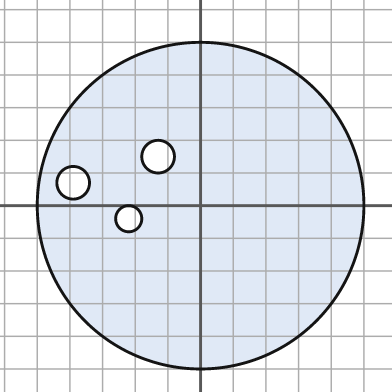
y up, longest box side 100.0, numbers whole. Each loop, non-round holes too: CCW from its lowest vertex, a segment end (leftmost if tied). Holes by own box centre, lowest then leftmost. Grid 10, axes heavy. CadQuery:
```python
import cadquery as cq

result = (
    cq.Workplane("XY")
    .moveTo(0.0, 0.0)
    .circle(50.0)
    .moveTo(-22.0, -4.0)
    .circle(4.0)
    .moveTo(-39.0, 7.0)
    .circle(5.0)
    .moveTo(-13.0, 15.0)
    .circle(5.0)
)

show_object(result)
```